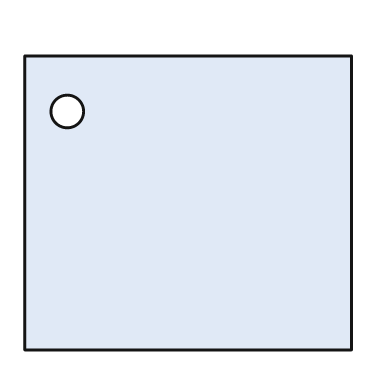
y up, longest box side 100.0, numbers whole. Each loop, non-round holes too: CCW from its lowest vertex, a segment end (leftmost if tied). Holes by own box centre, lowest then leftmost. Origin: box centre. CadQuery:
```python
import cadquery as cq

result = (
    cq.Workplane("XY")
    .moveTo(-50.0, -45.0)
    .lineTo(50.0, -45.0)
    .lineTo(50.0, 45.0)
    .lineTo(-50.0, 45.0)
    .close()
    .moveTo(-37.0, 28.0)
    .circle(5.0)
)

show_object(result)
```